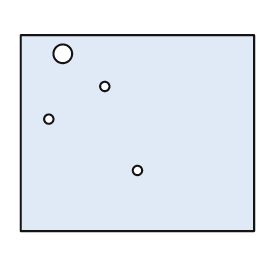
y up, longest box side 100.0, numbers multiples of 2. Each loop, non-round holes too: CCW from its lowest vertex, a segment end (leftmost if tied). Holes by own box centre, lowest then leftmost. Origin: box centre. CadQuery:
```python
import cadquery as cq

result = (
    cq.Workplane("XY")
    .moveTo(-50.0, -42.0)
    .lineTo(50.0, -42.0)
    .lineTo(50.0, 42.0)
    .lineTo(-50.0, 42.0)
    .close()
    .moveTo(0.0, -16.0)
    .circle(2.0)
    .moveTo(-38.0, 6.0)
    .circle(2.0)
    .moveTo(-14.0, 20.0)
    .circle(2.0)
    .moveTo(-32.0, 34.0)
    .circle(4.0)
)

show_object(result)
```